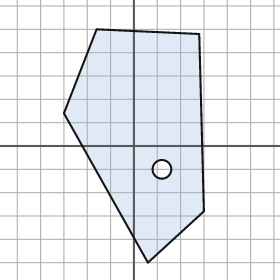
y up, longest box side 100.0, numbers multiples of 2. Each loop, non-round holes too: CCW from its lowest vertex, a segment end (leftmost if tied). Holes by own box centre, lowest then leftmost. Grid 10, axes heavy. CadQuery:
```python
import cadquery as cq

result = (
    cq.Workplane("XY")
    .moveTo(6.0, -50.0)
    .lineTo(30.0, -28.0)
    .lineTo(28.0, 48.0)
    .lineTo(-16.0, 50.0)
    .lineTo(-30.0, 14.0)
    .close()
    .moveTo(12.0, -10.0)
    .circle(4.0)
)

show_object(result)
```